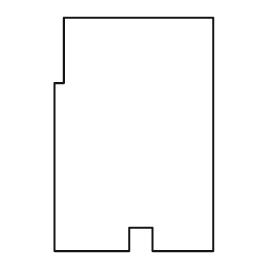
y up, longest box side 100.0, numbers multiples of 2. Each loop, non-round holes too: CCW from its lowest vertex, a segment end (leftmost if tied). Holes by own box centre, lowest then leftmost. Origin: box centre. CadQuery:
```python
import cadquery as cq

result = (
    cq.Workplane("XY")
    .moveTo(-34.0, -50.0)
    .lineTo(-2.0, -50.0)
    .lineTo(-2.0, -40.0)
    .lineTo(8.0, -40.0)
    .lineTo(8.0, -50.0)
    .lineTo(34.0, -50.0)
    .lineTo(34.0, 50.0)
    .lineTo(-30.0, 50.0)
    .lineTo(-30.0, 22.0)
    .lineTo(-34.0, 22.0)
    .close()
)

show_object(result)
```